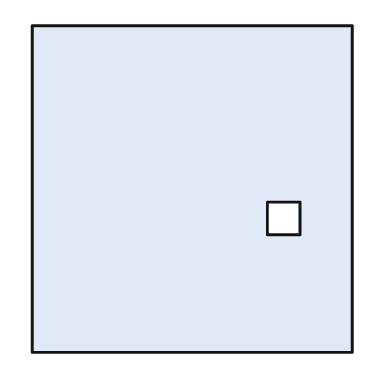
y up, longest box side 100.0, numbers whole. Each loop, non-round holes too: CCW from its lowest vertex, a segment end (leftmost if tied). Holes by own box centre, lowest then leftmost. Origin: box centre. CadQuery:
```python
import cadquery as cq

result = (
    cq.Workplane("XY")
    .moveTo(-49.0, -50.0)
    .lineTo(49.0, -50.0)
    .lineTo(49.0, 50.0)
    .lineTo(-49.0, 50.0)
    .close()
    .moveTo(23.0, -14.0)
    .lineTo(33.0, -14.0)
    .lineTo(33.0, -4.0)
    .lineTo(23.0, -4.0)
    .close()
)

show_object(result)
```